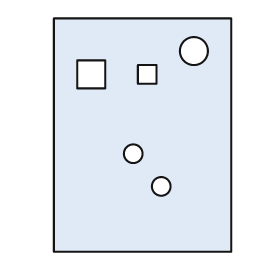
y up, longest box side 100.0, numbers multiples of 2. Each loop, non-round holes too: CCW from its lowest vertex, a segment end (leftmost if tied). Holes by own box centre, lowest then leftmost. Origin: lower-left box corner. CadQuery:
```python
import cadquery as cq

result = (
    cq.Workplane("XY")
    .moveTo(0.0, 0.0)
    .lineTo(76.0, 0.0)
    .lineTo(76.0, 100.0)
    .lineTo(0.0, 100.0)
    .close()
    .moveTo(46.0, 28.0)
    .circle(4.0)
    .moveTo(34.0, 42.0)
    .circle(4.0)
    .moveTo(10.0, 70.0)
    .lineTo(22.0, 70.0)
    .lineTo(22.0, 82.0)
    .lineTo(10.0, 82.0)
    .close()
    .moveTo(36.0, 72.0)
    .lineTo(44.0, 72.0)
    .lineTo(44.0, 80.0)
    .lineTo(36.0, 80.0)
    .close()
    .moveTo(60.0, 86.0)
    .circle(6.0)
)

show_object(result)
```